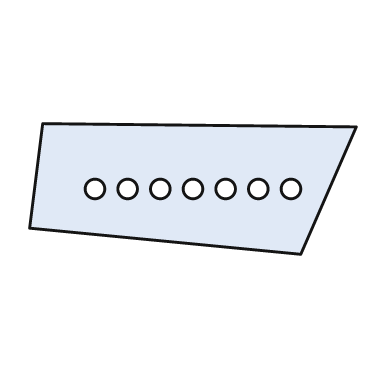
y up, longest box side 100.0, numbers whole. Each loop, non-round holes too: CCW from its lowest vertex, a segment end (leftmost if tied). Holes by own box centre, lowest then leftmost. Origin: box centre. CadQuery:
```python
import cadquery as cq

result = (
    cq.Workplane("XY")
    .moveTo(33.0, -20.0)
    .lineTo(50.0, 19.0)
    .lineTo(-46.0, 20.0)
    .lineTo(-50.0, -12.0)
    .close()
    .moveTo(-30.0, 0.0)
    .circle(3.0)
    .moveTo(-20.0, 0.0)
    .circle(3.0)
    .moveTo(-10.0, 0.0)
    .circle(3.0)
    .moveTo(0.0, 0.0)
    .circle(3.0)
    .moveTo(10.0, 0.0)
    .circle(3.0)
    .moveTo(20.0, 0.0)
    .circle(3.0)
    .moveTo(30.0, 0.0)
    .circle(3.0)
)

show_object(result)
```